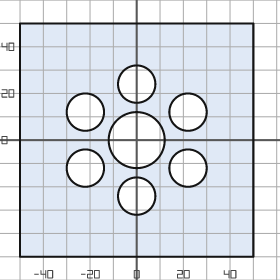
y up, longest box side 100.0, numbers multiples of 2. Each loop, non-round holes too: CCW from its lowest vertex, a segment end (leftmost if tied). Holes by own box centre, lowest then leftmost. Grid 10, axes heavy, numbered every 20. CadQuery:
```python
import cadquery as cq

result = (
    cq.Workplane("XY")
    .moveTo(-50.0, -50.0)
    .lineTo(50.0, -50.0)
    .lineTo(50.0, 50.0)
    .lineTo(-50.0, 50.0)
    .close()
    .moveTo(0.0, -24.0)
    .circle(8.0)
    .moveTo(-22.0, -12.0)
    .circle(8.0)
    .moveTo(22.0, -12.0)
    .circle(8.0)
    .moveTo(0.0, 0.0)
    .circle(12.0)
    .moveTo(-22.0, 12.0)
    .circle(8.0)
    .moveTo(22.0, 12.0)
    .circle(8.0)
    .moveTo(0.0, 24.0)
    .circle(8.0)
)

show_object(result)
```